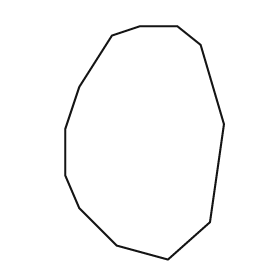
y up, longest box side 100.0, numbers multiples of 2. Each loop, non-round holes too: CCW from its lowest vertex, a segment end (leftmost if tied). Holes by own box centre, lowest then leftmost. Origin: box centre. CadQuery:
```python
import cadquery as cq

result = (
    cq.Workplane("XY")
    .moveTo(10.0, -50.0)
    .lineTo(28.0, -34.0)
    .lineTo(34.0, 8.0)
    .lineTo(24.0, 42.0)
    .lineTo(14.0, 50.0)
    .lineTo(-2.0, 50.0)
    .lineTo(-14.0, 46.0)
    .lineTo(-28.0, 24.0)
    .lineTo(-34.0, 6.0)
    .lineTo(-34.0, -14.0)
    .lineTo(-28.0, -28.0)
    .lineTo(-12.0, -44.0)
    .close()
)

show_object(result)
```